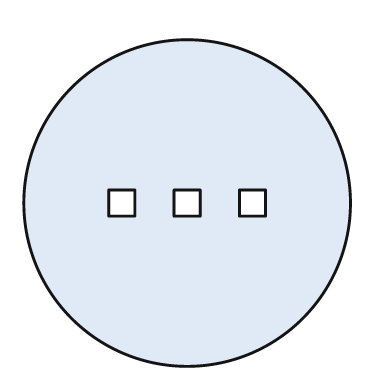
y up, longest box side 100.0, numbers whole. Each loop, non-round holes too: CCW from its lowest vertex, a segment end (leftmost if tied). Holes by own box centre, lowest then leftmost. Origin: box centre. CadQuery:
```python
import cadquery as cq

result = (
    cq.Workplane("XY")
    .moveTo(0.0, 0.0)
    .circle(50.0)
    .moveTo(-24.0, -4.0)
    .lineTo(-16.0, -4.0)
    .lineTo(-16.0, 4.0)
    .lineTo(-24.0, 4.0)
    .close()
    .moveTo(-4.0, -4.0)
    .lineTo(4.0, -4.0)
    .lineTo(4.0, 4.0)
    .lineTo(-4.0, 4.0)
    .close()
    .moveTo(16.0, -4.0)
    .lineTo(24.0, -4.0)
    .lineTo(24.0, 4.0)
    .lineTo(16.0, 4.0)
    .close()
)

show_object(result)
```